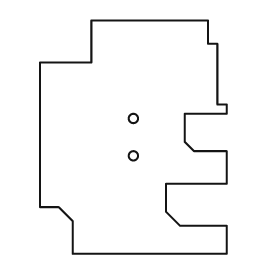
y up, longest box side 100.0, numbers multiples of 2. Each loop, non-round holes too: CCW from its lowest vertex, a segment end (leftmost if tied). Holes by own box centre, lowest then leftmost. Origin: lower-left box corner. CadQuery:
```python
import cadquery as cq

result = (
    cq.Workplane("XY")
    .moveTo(14.0, 0.0)
    .lineTo(80.0, 0.0)
    .lineTo(80.0, 12.0)
    .lineTo(60.0, 12.0)
    .lineTo(54.0, 18.0)
    .lineTo(54.0, 30.0)
    .lineTo(80.0, 30.0)
    .lineTo(80.0, 44.0)
    .lineTo(66.0, 44.0)
    .lineTo(62.0, 48.0)
    .lineTo(62.0, 60.0)
    .lineTo(80.0, 60.0)
    .lineTo(80.0, 64.0)
    .lineTo(76.0, 64.0)
    .lineTo(76.0, 90.0)
    .lineTo(72.0, 90.0)
    .lineTo(72.0, 100.0)
    .lineTo(22.0, 100.0)
    .lineTo(22.0, 82.0)
    .lineTo(0.0, 82.0)
    .lineTo(0.0, 20.0)
    .lineTo(8.0, 20.0)
    .lineTo(14.0, 14.0)
    .close()
    .moveTo(40.0, 42.0)
    .circle(2.0)
    .moveTo(40.0, 58.0)
    .circle(2.0)
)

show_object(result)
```